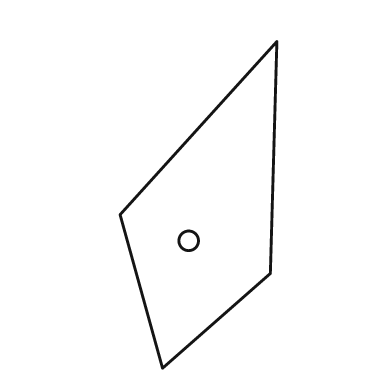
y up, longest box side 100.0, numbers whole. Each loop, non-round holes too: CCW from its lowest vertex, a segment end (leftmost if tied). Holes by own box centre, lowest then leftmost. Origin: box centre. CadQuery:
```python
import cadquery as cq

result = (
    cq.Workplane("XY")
    .moveTo(-11.0, -50.0)
    .lineTo(22.0, -21.0)
    .lineTo(24.0, 50.0)
    .lineTo(-24.0, -3.0)
    .close()
    .moveTo(-3.0, -11.0)
    .circle(3.0)
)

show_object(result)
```